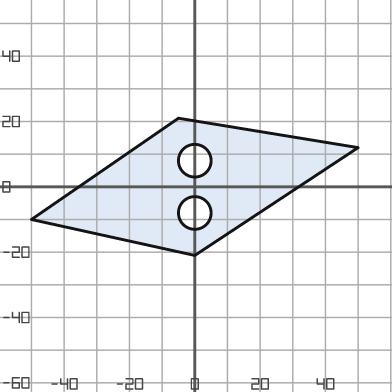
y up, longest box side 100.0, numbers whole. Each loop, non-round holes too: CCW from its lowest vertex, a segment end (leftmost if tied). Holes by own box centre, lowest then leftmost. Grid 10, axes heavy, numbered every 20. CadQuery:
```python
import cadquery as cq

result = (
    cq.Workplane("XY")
    .moveTo(0.0, -21.0)
    .lineTo(50.0, 12.0)
    .lineTo(-5.0, 21.0)
    .lineTo(-50.0, -10.0)
    .close()
    .moveTo(0.0, -8.0)
    .circle(5.0)
    .moveTo(0.0, 8.0)
    .circle(5.0)
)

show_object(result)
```